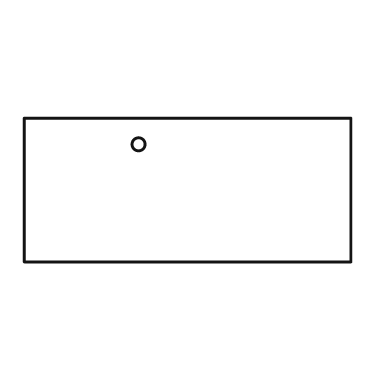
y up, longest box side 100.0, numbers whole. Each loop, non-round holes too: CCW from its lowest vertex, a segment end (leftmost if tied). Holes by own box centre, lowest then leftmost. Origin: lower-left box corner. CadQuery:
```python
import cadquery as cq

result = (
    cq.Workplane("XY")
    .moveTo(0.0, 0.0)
    .lineTo(100.0, 0.0)
    .lineTo(100.0, 44.0)
    .lineTo(0.0, 44.0)
    .close()
    .moveTo(35.0, 36.0)
    .circle(2.0)
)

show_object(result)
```